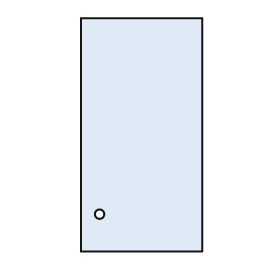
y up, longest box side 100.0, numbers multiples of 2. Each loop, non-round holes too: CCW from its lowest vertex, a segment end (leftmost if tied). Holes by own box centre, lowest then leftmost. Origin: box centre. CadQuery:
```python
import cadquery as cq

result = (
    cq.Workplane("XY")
    .moveTo(-26.0, -50.0)
    .lineTo(26.0, -50.0)
    .lineTo(26.0, 50.0)
    .lineTo(-26.0, 50.0)
    .close()
    .moveTo(-18.0, -34.0)
    .circle(2.0)
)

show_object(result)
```